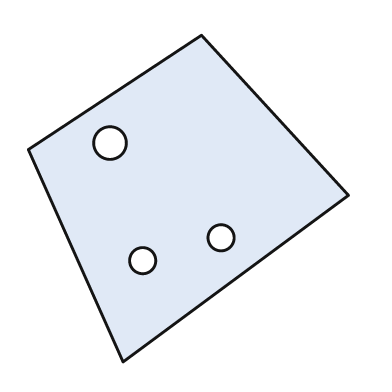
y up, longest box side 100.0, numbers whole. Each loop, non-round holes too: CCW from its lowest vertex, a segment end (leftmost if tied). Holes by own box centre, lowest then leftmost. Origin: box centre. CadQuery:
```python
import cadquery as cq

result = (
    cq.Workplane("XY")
    .moveTo(-20.0, -50.0)
    .lineTo(49.0, 1.0)
    .lineTo(4.0, 50.0)
    .lineTo(-49.0, 15.0)
    .close()
    .moveTo(-14.0, -19.0)
    .circle(4.0)
    .moveTo(10.0, -12.0)
    .circle(4.0)
    .moveTo(-24.0, 17.0)
    .circle(5.0)
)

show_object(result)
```